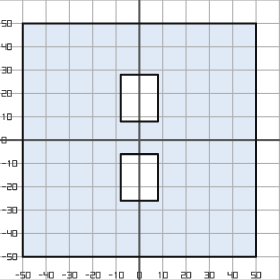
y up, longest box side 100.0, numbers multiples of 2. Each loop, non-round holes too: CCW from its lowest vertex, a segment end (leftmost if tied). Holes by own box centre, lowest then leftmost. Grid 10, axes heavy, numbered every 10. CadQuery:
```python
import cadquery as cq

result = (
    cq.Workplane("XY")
    .moveTo(-50.0, -50.0)
    .lineTo(50.0, -50.0)
    .lineTo(50.0, 50.0)
    .lineTo(-50.0, 50.0)
    .close()
    .moveTo(-8.0, -26.0)
    .lineTo(8.0, -26.0)
    .lineTo(8.0, -6.0)
    .lineTo(-8.0, -6.0)
    .close()
    .moveTo(-8.0, 8.0)
    .lineTo(8.0, 8.0)
    .lineTo(8.0, 28.0)
    .lineTo(-8.0, 28.0)
    .close()
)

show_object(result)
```